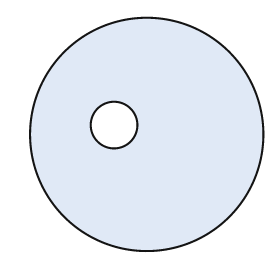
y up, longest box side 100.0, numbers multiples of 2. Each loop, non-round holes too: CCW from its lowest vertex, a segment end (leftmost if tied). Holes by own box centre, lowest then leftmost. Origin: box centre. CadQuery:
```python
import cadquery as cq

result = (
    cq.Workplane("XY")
    .moveTo(0.0, 0.0)
    .circle(50.0)
    .moveTo(-14.0, 4.0)
    .circle(10.0)
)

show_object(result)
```